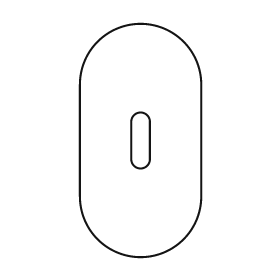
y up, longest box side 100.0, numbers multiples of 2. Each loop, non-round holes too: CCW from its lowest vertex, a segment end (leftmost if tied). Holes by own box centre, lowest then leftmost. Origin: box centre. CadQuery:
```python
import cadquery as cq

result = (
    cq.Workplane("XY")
    .moveTo(-26.0, -24.0)
    .threePointArc((0.0, -50.0), (26.0, -24.0))
    .lineTo(26.0, 24.0)
    .threePointArc((0.0, 50.0), (-26.0, 24.0))
    .close()
    .moveTo(-4.0, -8.0)
    .threePointArc((0.0, -12.0), (4.0, -8.0))
    .lineTo(4.0, 8.0)
    .threePointArc((0.0, 12.0), (-4.0, 8.0))
    .close()
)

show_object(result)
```